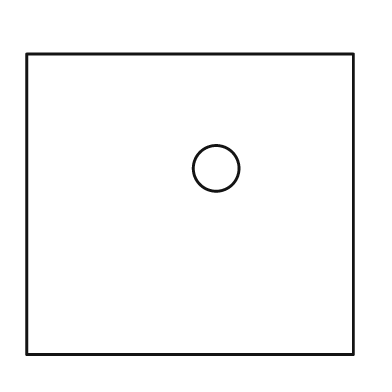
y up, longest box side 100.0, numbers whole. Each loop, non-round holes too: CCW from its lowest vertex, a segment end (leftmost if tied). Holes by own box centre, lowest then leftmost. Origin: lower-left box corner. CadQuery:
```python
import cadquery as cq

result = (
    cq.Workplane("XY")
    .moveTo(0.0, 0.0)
    .lineTo(100.0, 0.0)
    .lineTo(100.0, 92.0)
    .lineTo(0.0, 92.0)
    .close()
    .moveTo(58.0, 57.0)
    .circle(7.0)
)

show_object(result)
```